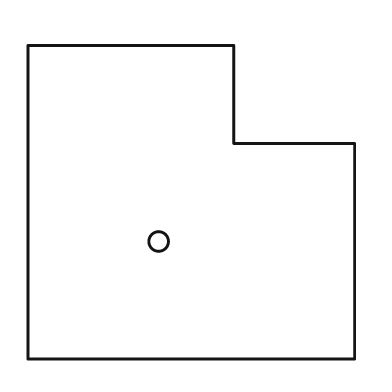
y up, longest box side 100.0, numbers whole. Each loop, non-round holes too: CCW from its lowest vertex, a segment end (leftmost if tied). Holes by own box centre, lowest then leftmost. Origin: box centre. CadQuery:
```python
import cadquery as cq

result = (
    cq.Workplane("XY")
    .moveTo(-50.0, -48.0)
    .lineTo(50.0, -48.0)
    .lineTo(50.0, 18.0)
    .lineTo(13.0, 18.0)
    .lineTo(13.0, 48.0)
    .lineTo(-50.0, 48.0)
    .close()
    .moveTo(-10.0, -12.0)
    .circle(3.0)
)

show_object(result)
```